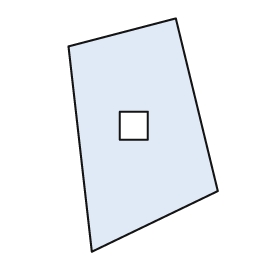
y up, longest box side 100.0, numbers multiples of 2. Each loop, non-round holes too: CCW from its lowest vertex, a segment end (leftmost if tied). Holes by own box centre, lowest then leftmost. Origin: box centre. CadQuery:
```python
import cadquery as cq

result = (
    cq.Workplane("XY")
    .moveTo(-22.0, -50.0)
    .lineTo(32.0, -24.0)
    .lineTo(14.0, 50.0)
    .lineTo(-32.0, 38.0)
    .close()
    .moveTo(-10.0, -2.0)
    .lineTo(2.0, -2.0)
    .lineTo(2.0, 10.0)
    .lineTo(-10.0, 10.0)
    .close()
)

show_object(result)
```